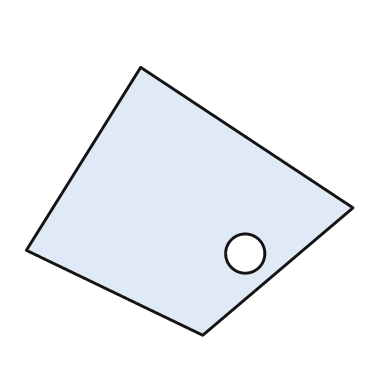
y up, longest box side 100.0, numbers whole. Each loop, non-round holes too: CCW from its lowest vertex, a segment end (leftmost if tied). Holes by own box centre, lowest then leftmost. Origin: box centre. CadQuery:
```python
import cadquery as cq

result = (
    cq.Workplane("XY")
    .moveTo(4.0, -41.0)
    .lineTo(50.0, -2.0)
    .lineTo(-15.0, 41.0)
    .lineTo(-50.0, -15.0)
    .close()
    .moveTo(17.0, -16.0)
    .circle(6.0)
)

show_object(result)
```